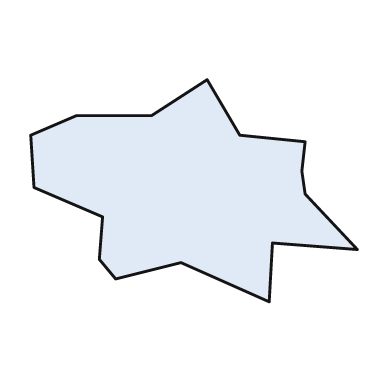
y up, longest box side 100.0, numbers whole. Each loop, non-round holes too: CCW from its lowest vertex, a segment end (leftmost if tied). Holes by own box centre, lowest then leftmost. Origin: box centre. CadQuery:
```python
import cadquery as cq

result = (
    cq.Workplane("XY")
    .moveTo(23.0, -34.0)
    .lineTo(24.0, -16.0)
    .lineTo(50.0, -18.0)
    .lineTo(34.0, -1.0)
    .lineTo(33.0, 6.0)
    .lineTo(34.0, 15.0)
    .lineTo(14.0, 17.0)
    .lineTo(4.0, 34.0)
    .lineTo(-13.0, 23.0)
    .lineTo(-36.0, 23.0)
    .lineTo(-50.0, 17.0)
    .lineTo(-49.0, 1.0)
    .lineTo(-28.0, -8.0)
    .lineTo(-29.0, -21.0)
    .lineTo(-24.0, -27.0)
    .lineTo(-4.0, -22.0)
    .close()
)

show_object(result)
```